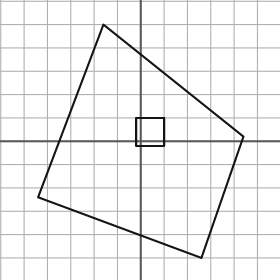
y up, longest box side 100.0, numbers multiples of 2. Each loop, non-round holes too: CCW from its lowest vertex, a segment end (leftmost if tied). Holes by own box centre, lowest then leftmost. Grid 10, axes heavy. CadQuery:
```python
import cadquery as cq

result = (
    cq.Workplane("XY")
    .moveTo(26.0, -50.0)
    .lineTo(44.0, 2.0)
    .lineTo(-16.0, 50.0)
    .lineTo(-44.0, -24.0)
    .close()
    .moveTo(-2.0, -2.0)
    .lineTo(10.0, -2.0)
    .lineTo(10.0, 10.0)
    .lineTo(-2.0, 10.0)
    .close()
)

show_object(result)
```